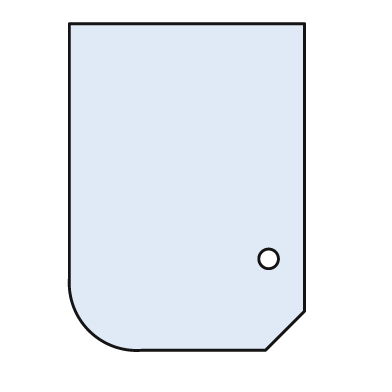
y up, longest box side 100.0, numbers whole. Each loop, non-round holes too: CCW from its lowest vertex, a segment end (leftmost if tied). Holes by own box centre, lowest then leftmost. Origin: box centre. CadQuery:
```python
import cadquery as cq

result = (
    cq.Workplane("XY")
    .moveTo(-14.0, -50.0)
    .lineTo(24.0, -50.0)
    .lineTo(36.0, -38.0)
    .lineTo(36.0, 50.0)
    .lineTo(-36.0, 50.0)
    .lineTo(-36.0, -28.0)
    .threePointArc((-30.0, -44.0), (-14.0, -50.0))
    .close()
    .moveTo(25.0, -22.0)
    .circle(3.0)
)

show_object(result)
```